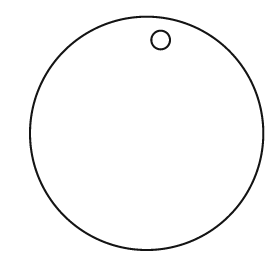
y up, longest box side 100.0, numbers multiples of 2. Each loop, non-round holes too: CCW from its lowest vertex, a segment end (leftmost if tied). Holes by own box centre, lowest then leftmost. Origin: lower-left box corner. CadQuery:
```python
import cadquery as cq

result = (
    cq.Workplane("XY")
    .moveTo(50.0, 50.0)
    .circle(50.0)
    .moveTo(56.0, 90.0)
    .circle(4.0)
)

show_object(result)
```